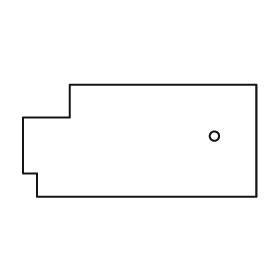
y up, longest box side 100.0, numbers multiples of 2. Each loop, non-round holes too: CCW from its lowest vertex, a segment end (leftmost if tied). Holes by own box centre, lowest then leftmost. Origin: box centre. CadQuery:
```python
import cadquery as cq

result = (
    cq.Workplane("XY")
    .moveTo(-44.0, -24.0)
    .lineTo(50.0, -24.0)
    .lineTo(50.0, 24.0)
    .lineTo(-30.0, 24.0)
    .lineTo(-30.0, 10.0)
    .lineTo(-50.0, 10.0)
    .lineTo(-50.0, -14.0)
    .lineTo(-44.0, -14.0)
    .close()
    .moveTo(32.0, 2.0)
    .circle(2.0)
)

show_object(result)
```